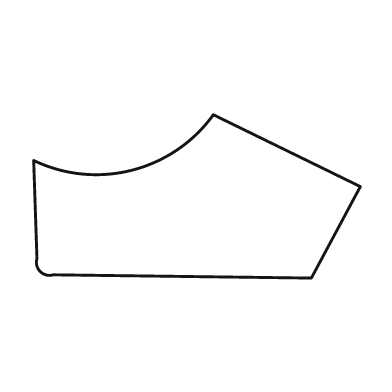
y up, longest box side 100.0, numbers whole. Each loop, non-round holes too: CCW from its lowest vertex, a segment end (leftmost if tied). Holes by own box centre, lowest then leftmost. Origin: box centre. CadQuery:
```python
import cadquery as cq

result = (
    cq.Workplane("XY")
    .moveTo(35.0, -25.0)
    .lineTo(50.0, 3.0)
    .lineTo(5.0, 25.0)
    .threePointArc((-20.0, 8.0), (-50.0, 11.0))
    .lineTo(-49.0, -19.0)
    .threePointArc((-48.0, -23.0), (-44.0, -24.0))
    .close()
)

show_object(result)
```